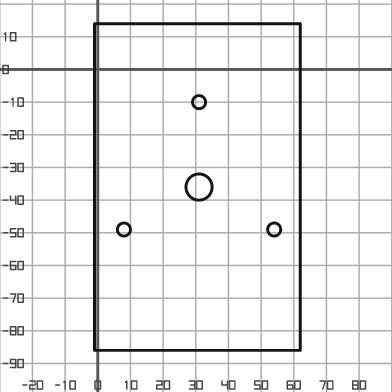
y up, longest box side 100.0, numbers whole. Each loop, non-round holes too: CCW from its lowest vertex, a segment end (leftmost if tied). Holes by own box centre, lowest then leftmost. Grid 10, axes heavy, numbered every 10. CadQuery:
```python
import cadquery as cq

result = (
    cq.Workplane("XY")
    .moveTo(-1.0, -86.0)
    .lineTo(62.0, -86.0)
    .lineTo(62.0, 14.0)
    .lineTo(-1.0, 14.0)
    .close()
    .moveTo(8.0, -49.0)
    .circle(2.0)
    .moveTo(54.0, -49.0)
    .circle(2.0)
    .moveTo(31.0, -36.0)
    .circle(4.0)
    .moveTo(31.0, -10.0)
    .circle(2.0)
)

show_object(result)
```